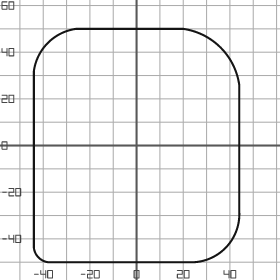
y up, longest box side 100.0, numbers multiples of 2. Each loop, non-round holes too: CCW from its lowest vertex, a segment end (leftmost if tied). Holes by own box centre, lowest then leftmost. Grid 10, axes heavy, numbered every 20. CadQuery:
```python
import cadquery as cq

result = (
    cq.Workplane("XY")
    .moveTo(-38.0, -50.0)
    .lineTo(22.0, -50.0)
    .threePointArc((38.0, -44.0), (44.0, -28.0))
    .lineTo(44.0, 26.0)
    .threePointArc((36.0, 42.0), (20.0, 50.0))
    .lineTo(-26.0, 50.0)
    .threePointArc((-38.0, 44.0), (-44.0, 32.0))
    .lineTo(-44.0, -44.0)
    .threePointArc((-42.0, -48.0), (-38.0, -50.0))
    .close()
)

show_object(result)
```